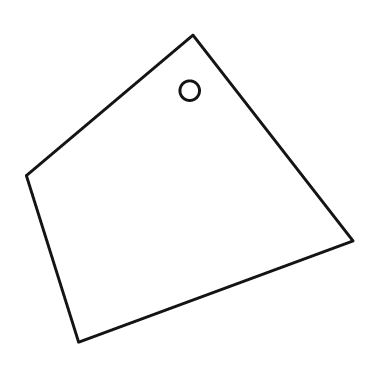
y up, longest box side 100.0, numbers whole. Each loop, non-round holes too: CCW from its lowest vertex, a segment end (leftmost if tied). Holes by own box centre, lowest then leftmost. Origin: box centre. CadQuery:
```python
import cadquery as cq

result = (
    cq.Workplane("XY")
    .moveTo(-34.0, -47.0)
    .lineTo(50.0, -16.0)
    .lineTo(1.0, 47.0)
    .lineTo(-50.0, 4.0)
    .close()
    .moveTo(0.0, 30.0)
    .circle(3.0)
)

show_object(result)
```